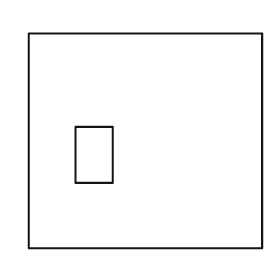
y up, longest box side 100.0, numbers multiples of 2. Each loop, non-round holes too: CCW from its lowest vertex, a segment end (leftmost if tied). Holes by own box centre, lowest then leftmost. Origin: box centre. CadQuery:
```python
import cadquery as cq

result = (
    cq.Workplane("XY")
    .moveTo(-50.0, -46.0)
    .lineTo(50.0, -46.0)
    .lineTo(50.0, 46.0)
    .lineTo(-50.0, 46.0)
    .close()
    .moveTo(-30.0, -18.0)
    .lineTo(-14.0, -18.0)
    .lineTo(-14.0, 6.0)
    .lineTo(-30.0, 6.0)
    .close()
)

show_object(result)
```